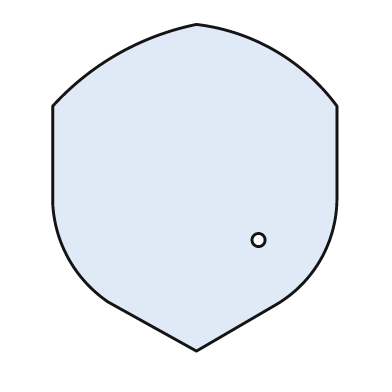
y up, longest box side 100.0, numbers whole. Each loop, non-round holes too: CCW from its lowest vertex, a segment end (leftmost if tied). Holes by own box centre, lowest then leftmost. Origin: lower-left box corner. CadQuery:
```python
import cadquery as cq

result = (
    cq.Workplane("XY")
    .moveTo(44.0, 0.0)
    .lineTo(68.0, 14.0)
    .threePointArc((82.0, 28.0), (87.0, 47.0))
    .lineTo(87.0, 75.0)
    .threePointArc((68.0, 92.0), (44.0, 100.0))
    .threePointArc((20.0, 91.0), (0.0, 75.0))
    .lineTo(0.0, 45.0)
    .threePointArc((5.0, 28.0), (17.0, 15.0))
    .close()
    .moveTo(63.0, 34.0)
    .circle(2.0)
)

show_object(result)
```